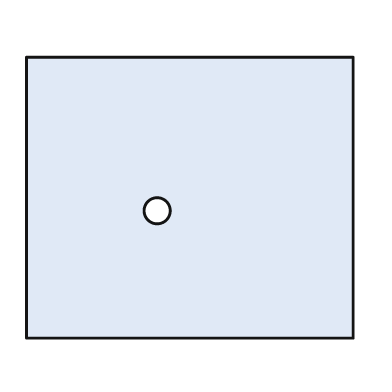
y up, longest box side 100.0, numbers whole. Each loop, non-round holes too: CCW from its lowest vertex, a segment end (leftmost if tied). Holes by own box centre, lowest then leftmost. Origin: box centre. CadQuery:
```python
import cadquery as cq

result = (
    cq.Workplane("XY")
    .moveTo(-50.0, -43.0)
    .lineTo(50.0, -43.0)
    .lineTo(50.0, 43.0)
    .lineTo(-50.0, 43.0)
    .close()
    .moveTo(-10.0, -4.0)
    .circle(4.0)
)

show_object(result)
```